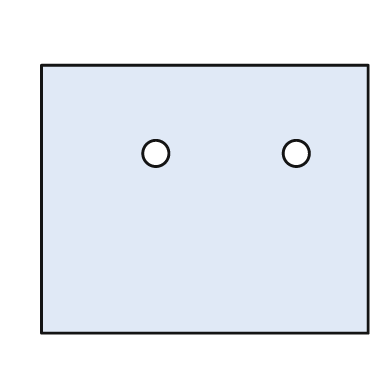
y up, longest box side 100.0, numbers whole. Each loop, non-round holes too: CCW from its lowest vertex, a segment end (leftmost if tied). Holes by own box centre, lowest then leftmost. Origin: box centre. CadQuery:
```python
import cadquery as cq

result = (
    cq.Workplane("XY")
    .moveTo(-50.0, -41.0)
    .lineTo(50.0, -41.0)
    .lineTo(50.0, 41.0)
    .lineTo(-50.0, 41.0)
    .close()
    .moveTo(-15.0, 14.0)
    .circle(4.0)
    .moveTo(28.0, 14.0)
    .circle(4.0)
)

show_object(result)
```